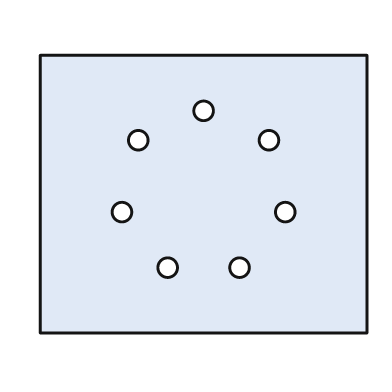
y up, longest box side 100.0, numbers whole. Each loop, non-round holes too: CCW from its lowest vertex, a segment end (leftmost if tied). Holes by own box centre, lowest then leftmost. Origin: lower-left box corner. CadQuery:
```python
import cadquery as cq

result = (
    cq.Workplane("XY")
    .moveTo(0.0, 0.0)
    .lineTo(100.0, 0.0)
    .lineTo(100.0, 85.0)
    .lineTo(0.0, 85.0)
    .close()
    .moveTo(39.0, 20.0)
    .circle(3.0)
    .moveTo(61.0, 20.0)
    .circle(3.0)
    .moveTo(25.0, 37.0)
    .circle(3.0)
    .moveTo(75.0, 37.0)
    .circle(3.0)
    .moveTo(30.0, 59.0)
    .circle(3.0)
    .moveTo(70.0, 59.0)
    .circle(3.0)
    .moveTo(50.0, 68.0)
    .circle(3.0)
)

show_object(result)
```